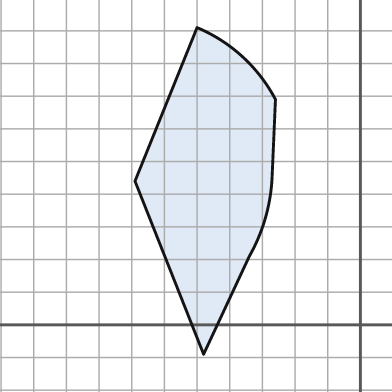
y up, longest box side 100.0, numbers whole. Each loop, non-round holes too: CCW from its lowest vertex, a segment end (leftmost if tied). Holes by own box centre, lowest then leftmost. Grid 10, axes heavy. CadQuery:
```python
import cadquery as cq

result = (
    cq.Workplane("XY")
    .moveTo(-48.0, -9.0)
    .lineTo(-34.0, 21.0)
    .threePointArc((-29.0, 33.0), (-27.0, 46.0))
    .lineTo(-26.0, 69.0)
    .threePointArc((-36.0, 82.0), (-50.0, 91.0))
    .lineTo(-69.0, 44.0)
    .close()
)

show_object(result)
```